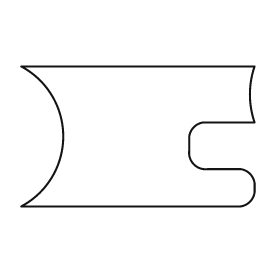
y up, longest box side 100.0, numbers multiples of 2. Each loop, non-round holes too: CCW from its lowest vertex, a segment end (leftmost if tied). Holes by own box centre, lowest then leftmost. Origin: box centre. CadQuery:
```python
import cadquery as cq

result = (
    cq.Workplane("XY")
    .moveTo(-50.0, -30.0)
    .lineTo(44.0, -30.0)
    .threePointArc((48.0, -28.0), (50.0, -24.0))
    .lineTo(50.0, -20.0)
    .threePointArc((48.0, -16.0), (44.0, -14.0))
    .lineTo(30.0, -14.0)
    .threePointArc((24.0, -12.0), (22.0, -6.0))
    .lineTo(22.0, 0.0)
    .threePointArc((24.0, 4.0), (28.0, 6.0))
    .lineTo(50.0, 6.0)
    .threePointArc((48.0, 18.0), (50.0, 30.0))
    .lineTo(-50.0, 30.0)
    .threePointArc((-32.0, 0.0), (-50.0, -30.0))
    .close()
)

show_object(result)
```